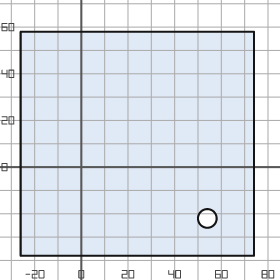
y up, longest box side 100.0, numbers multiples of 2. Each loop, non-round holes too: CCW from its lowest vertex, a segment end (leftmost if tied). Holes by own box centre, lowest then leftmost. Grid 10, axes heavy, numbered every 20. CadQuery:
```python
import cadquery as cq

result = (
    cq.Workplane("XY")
    .moveTo(-26.0, -38.0)
    .lineTo(74.0, -38.0)
    .lineTo(74.0, 58.0)
    .lineTo(-26.0, 58.0)
    .close()
    .moveTo(54.0, -22.0)
    .circle(4.0)
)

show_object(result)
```